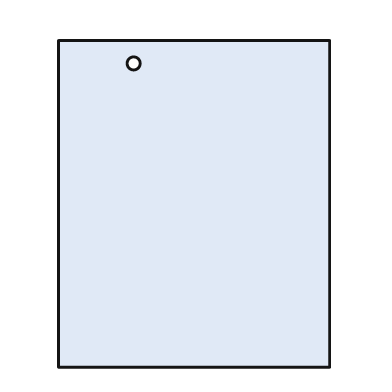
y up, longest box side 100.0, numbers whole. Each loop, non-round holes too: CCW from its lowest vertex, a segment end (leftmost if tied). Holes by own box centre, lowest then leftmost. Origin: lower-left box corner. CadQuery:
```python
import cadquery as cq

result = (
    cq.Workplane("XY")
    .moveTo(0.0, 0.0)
    .lineTo(83.0, 0.0)
    .lineTo(83.0, 100.0)
    .lineTo(0.0, 100.0)
    .close()
    .moveTo(23.0, 93.0)
    .circle(2.0)
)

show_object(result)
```